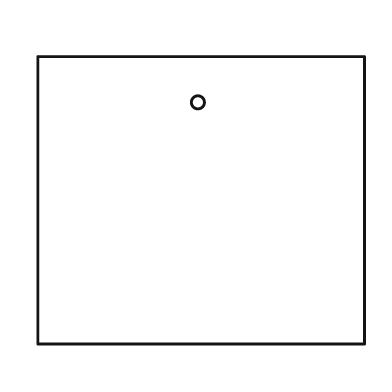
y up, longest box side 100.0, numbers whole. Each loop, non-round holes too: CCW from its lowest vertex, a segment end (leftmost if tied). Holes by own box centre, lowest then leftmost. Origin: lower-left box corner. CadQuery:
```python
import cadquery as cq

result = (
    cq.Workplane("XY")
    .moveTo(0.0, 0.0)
    .lineTo(100.0, 0.0)
    .lineTo(100.0, 88.0)
    .lineTo(0.0, 88.0)
    .close()
    .moveTo(49.0, 74.0)
    .circle(2.0)
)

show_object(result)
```